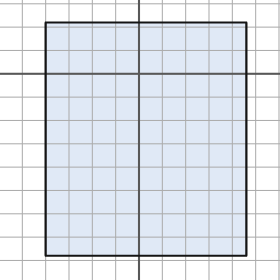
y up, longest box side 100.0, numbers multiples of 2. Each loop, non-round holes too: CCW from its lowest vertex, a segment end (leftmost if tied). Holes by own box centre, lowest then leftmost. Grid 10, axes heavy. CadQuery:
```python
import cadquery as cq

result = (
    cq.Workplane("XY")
    .moveTo(-40.0, -78.0)
    .lineTo(46.0, -78.0)
    .lineTo(46.0, 22.0)
    .lineTo(-40.0, 22.0)
    .close()
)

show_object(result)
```